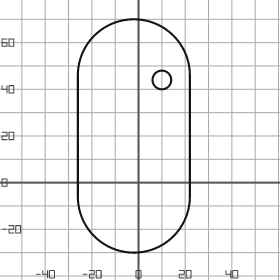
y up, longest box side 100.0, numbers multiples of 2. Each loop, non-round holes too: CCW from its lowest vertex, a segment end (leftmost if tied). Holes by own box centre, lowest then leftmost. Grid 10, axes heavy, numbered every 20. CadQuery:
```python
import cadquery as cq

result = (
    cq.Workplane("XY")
    .moveTo(-26.0, -6.0)
    .threePointArc((-2.0, -30.0), (22.0, -6.0))
    .lineTo(22.0, 46.0)
    .threePointArc((-2.0, 70.0), (-26.0, 46.0))
    .close()
    .moveTo(10.0, 44.0)
    .circle(4.0)
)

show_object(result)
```